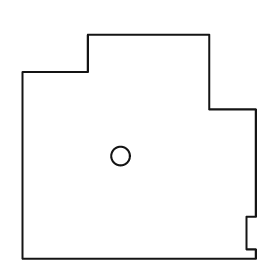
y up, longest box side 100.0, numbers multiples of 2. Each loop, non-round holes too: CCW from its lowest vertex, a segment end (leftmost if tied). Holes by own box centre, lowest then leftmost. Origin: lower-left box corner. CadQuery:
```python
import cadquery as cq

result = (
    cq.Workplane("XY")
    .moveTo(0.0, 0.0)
    .lineTo(100.0, 0.0)
    .lineTo(100.0, 4.0)
    .lineTo(96.0, 4.0)
    .lineTo(96.0, 18.0)
    .lineTo(100.0, 18.0)
    .lineTo(100.0, 64.0)
    .lineTo(80.0, 64.0)
    .lineTo(80.0, 96.0)
    .lineTo(28.0, 96.0)
    .lineTo(28.0, 80.0)
    .lineTo(0.0, 80.0)
    .close()
    .moveTo(42.0, 44.0)
    .circle(4.0)
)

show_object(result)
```